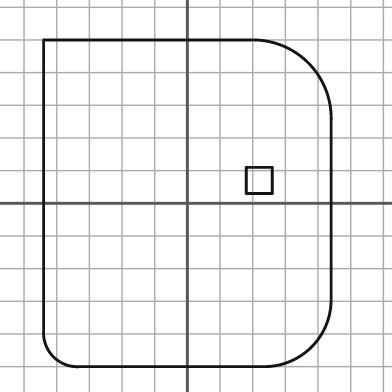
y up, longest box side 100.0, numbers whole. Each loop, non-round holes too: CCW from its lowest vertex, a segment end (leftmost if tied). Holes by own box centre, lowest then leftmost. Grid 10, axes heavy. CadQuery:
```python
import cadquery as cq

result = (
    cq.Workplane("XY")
    .moveTo(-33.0, -50.0)
    .lineTo(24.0, -50.0)
    .threePointArc((38.0, -44.0), (44.0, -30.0))
    .lineTo(44.0, 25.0)
    .threePointArc((37.0, 43.0), (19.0, 50.0))
    .lineTo(-44.0, 50.0)
    .lineTo(-44.0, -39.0)
    .threePointArc((-41.0, -47.0), (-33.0, -50.0))
    .close()
    .moveTo(18.0, 3.0)
    .lineTo(26.0, 3.0)
    .lineTo(26.0, 11.0)
    .lineTo(18.0, 11.0)
    .close()
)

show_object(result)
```